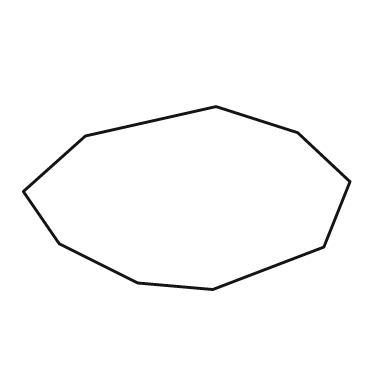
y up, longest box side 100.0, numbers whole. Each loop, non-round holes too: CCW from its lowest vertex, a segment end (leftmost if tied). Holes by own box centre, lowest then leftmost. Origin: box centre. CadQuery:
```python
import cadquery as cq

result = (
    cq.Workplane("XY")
    .moveTo(8.0, -28.0)
    .lineTo(42.0, -15.0)
    .lineTo(50.0, 5.0)
    .lineTo(34.0, 20.0)
    .lineTo(9.0, 28.0)
    .lineTo(-31.0, 19.0)
    .lineTo(-50.0, 2.0)
    .lineTo(-39.0, -14.0)
    .lineTo(-15.0, -26.0)
    .close()
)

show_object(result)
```